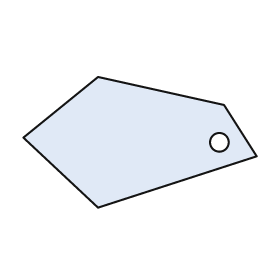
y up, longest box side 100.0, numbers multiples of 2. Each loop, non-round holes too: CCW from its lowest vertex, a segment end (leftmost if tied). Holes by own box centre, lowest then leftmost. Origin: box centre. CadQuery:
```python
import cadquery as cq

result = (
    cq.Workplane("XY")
    .moveTo(-18.0, -28.0)
    .lineTo(50.0, -6.0)
    .lineTo(36.0, 16.0)
    .lineTo(-18.0, 28.0)
    .lineTo(-50.0, 2.0)
    .close()
    .moveTo(34.0, 0.0)
    .circle(4.0)
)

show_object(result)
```